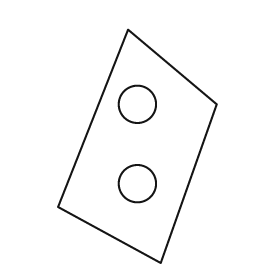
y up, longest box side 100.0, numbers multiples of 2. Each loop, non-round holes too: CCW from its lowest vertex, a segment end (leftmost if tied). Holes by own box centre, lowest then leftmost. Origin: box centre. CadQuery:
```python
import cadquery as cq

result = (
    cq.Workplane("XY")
    .moveTo(10.0, -50.0)
    .lineTo(34.0, 18.0)
    .lineTo(-4.0, 50.0)
    .lineTo(-34.0, -26.0)
    .close()
    .moveTo(0.0, -16.0)
    .circle(8.0)
    .moveTo(0.0, 18.0)
    .circle(8.0)
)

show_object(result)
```